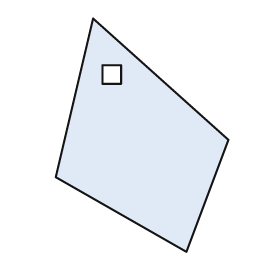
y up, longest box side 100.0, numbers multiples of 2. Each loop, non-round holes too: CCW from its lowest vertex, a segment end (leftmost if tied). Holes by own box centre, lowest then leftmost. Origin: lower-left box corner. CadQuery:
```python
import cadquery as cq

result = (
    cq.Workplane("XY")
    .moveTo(56.0, 0.0)
    .lineTo(74.0, 48.0)
    .lineTo(16.0, 100.0)
    .lineTo(0.0, 32.0)
    .close()
    .moveTo(20.0, 72.0)
    .lineTo(28.0, 72.0)
    .lineTo(28.0, 80.0)
    .lineTo(20.0, 80.0)
    .close()
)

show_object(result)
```